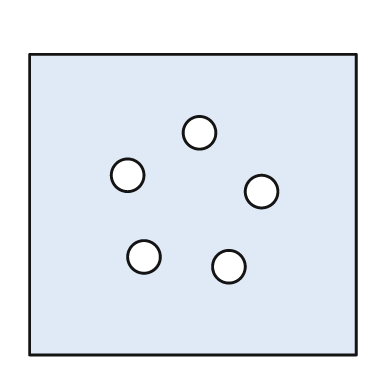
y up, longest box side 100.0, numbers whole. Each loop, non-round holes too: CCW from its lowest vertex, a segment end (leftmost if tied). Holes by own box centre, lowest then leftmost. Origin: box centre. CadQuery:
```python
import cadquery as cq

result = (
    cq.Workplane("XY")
    .moveTo(-50.0, -46.0)
    .lineTo(50.0, -46.0)
    .lineTo(50.0, 46.0)
    .lineTo(-50.0, 46.0)
    .close()
    .moveTo(11.0, -19.0)
    .circle(5.0)
    .moveTo(-15.0, -16.0)
    .circle(5.0)
    .moveTo(21.0, 4.0)
    .circle(5.0)
    .moveTo(-20.0, 9.0)
    .circle(5.0)
    .moveTo(2.0, 22.0)
    .circle(5.0)
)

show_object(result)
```